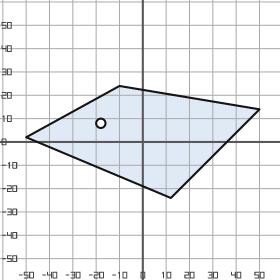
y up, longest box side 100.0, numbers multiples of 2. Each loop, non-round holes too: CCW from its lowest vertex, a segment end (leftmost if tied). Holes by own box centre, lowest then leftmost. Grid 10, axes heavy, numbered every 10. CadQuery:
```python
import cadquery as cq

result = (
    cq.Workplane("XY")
    .moveTo(12.0, -24.0)
    .lineTo(50.0, 14.0)
    .lineTo(-10.0, 24.0)
    .lineTo(-50.0, 2.0)
    .close()
    .moveTo(-18.0, 8.0)
    .circle(2.0)
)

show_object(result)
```